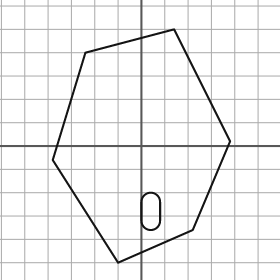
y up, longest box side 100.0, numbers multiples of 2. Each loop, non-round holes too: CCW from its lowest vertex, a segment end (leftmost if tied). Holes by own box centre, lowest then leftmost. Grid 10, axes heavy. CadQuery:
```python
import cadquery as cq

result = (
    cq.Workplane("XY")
    .moveTo(-10.0, -50.0)
    .lineTo(22.0, -36.0)
    .lineTo(38.0, 2.0)
    .lineTo(14.0, 50.0)
    .lineTo(-24.0, 40.0)
    .lineTo(-38.0, -6.0)
    .close()
    .moveTo(0.0, -32.0)
    .threePointArc((4.0, -36.0), (8.0, -32.0))
    .lineTo(8.0, -24.0)
    .threePointArc((4.0, -20.0), (0.0, -24.0))
    .close()
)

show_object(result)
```